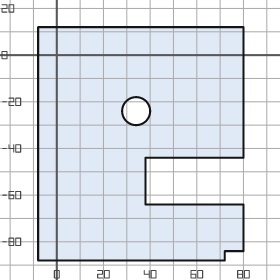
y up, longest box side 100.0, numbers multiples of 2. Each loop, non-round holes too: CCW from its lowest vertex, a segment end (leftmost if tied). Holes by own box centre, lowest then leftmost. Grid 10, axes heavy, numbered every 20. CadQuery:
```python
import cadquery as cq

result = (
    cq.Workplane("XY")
    .moveTo(-8.0, -88.0)
    .lineTo(72.0, -88.0)
    .lineTo(72.0, -84.0)
    .lineTo(80.0, -84.0)
    .lineTo(80.0, -64.0)
    .lineTo(38.0, -64.0)
    .lineTo(38.0, -44.0)
    .lineTo(80.0, -44.0)
    .lineTo(80.0, 12.0)
    .lineTo(-8.0, 12.0)
    .close()
    .moveTo(34.0, -24.0)
    .circle(6.0)
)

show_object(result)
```